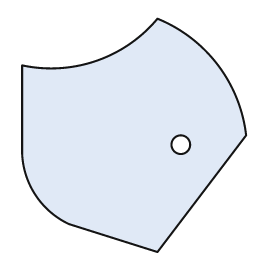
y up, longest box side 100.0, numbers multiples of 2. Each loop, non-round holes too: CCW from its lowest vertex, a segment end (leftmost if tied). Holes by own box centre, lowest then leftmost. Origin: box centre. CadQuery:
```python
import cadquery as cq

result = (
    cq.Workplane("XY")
    .moveTo(10.0, -50.0)
    .lineTo(48.0, 0.0)
    .threePointArc((36.0, 30.0), (10.0, 50.0))
    .threePointArc((-16.0, 32.0), (-48.0, 30.0))
    .lineTo(-48.0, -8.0)
    .threePointArc((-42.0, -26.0), (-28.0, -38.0))
    .close()
    .moveTo(20.0, -4.0)
    .circle(4.0)
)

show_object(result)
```